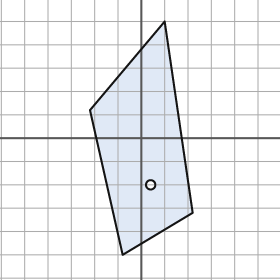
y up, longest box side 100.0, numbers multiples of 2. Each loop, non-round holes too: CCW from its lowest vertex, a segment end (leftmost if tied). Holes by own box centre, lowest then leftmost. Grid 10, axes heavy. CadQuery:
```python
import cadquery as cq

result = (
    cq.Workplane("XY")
    .moveTo(-8.0, -50.0)
    .lineTo(22.0, -32.0)
    .lineTo(10.0, 50.0)
    .lineTo(-22.0, 12.0)
    .close()
    .moveTo(4.0, -20.0)
    .circle(2.0)
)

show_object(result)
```